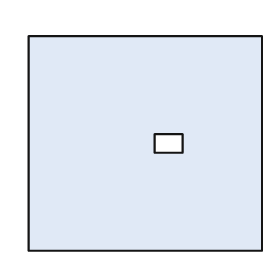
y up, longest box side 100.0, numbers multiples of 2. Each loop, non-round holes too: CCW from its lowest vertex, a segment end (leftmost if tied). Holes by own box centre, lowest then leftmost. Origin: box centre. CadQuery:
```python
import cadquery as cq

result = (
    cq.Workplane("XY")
    .moveTo(-50.0, -46.0)
    .lineTo(50.0, -46.0)
    .lineTo(50.0, 46.0)
    .lineTo(-50.0, 46.0)
    .close()
    .moveTo(4.0, -4.0)
    .lineTo(16.0, -4.0)
    .lineTo(16.0, 4.0)
    .lineTo(4.0, 4.0)
    .close()
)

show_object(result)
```